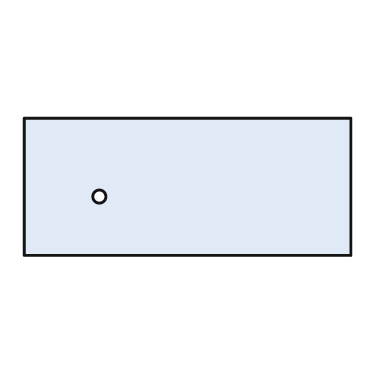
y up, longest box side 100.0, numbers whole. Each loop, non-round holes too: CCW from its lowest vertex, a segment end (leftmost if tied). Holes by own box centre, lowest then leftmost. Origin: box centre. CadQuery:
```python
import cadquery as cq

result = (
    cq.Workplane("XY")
    .moveTo(-50.0, -21.0)
    .lineTo(50.0, -21.0)
    .lineTo(50.0, 21.0)
    .lineTo(-50.0, 21.0)
    .close()
    .moveTo(-27.0, -3.0)
    .circle(2.0)
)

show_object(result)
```